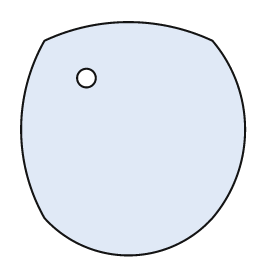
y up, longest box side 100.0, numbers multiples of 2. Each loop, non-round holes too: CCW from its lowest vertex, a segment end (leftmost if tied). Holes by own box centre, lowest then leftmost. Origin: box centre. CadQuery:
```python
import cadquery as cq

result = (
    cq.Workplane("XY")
    .moveTo(-38.0, -34.0)
    .threePointArc((-2.0, -50.0), (34.0, -34.0))
    .threePointArc((48.0, 4.0), (34.0, 42.0))
    .threePointArc((-2.0, 50.0), (-38.0, 42.0))
    .threePointArc((-48.0, 4.0), (-38.0, -34.0))
    .close()
    .moveTo(-20.0, 26.0)
    .circle(4.0)
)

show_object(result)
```